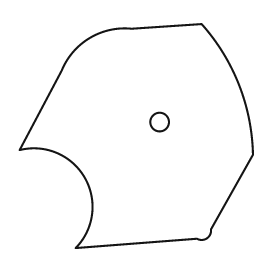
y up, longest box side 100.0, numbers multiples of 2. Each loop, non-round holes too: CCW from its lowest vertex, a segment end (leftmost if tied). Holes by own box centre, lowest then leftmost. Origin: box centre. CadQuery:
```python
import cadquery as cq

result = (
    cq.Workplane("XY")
    .moveTo(-26.0, -48.0)
    .lineTo(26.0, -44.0)
    .threePointArc((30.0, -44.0), (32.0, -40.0))
    .lineTo(50.0, -8.0)
    .threePointArc((44.0, 22.0), (28.0, 48.0))
    .lineTo(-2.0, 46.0)
    .threePointArc((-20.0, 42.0), (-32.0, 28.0))
    .lineTo(-50.0, -6.0)
    .threePointArc((-22.0, -18.0), (-26.0, -48.0))
    .close()
    .moveTo(10.0, 6.0)
    .circle(4.0)
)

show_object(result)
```